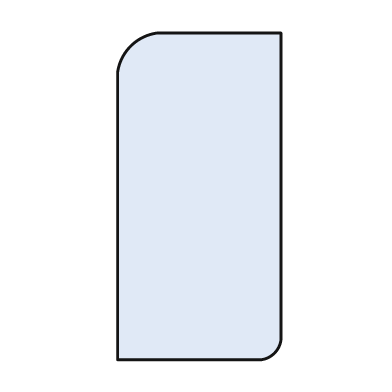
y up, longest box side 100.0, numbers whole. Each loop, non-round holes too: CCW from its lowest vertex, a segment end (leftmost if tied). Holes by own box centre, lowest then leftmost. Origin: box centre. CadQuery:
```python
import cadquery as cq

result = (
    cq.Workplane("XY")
    .moveTo(-25.0, -50.0)
    .lineTo(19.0, -50.0)
    .threePointArc((23.0, -48.0), (25.0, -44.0))
    .lineTo(25.0, 50.0)
    .lineTo(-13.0, 50.0)
    .threePointArc((-21.0, 46.0), (-25.0, 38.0))
    .close()
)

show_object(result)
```